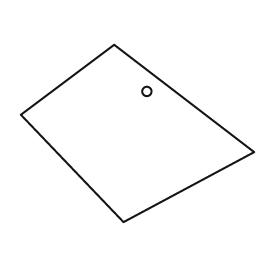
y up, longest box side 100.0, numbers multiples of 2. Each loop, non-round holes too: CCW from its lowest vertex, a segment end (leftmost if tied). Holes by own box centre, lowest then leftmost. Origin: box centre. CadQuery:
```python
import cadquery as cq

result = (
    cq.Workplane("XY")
    .moveTo(-6.0, -38.0)
    .lineTo(50.0, -8.0)
    .lineTo(-10.0, 38.0)
    .lineTo(-50.0, 8.0)
    .close()
    .moveTo(4.0, 18.0)
    .circle(2.0)
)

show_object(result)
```